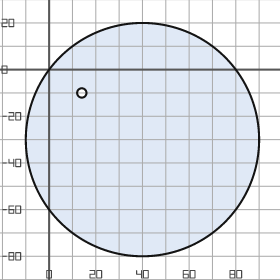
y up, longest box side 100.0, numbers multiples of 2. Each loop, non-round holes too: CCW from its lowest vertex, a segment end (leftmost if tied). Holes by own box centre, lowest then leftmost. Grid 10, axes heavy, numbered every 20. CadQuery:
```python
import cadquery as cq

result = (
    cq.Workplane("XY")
    .moveTo(40.0, -30.0)
    .circle(50.0)
    .moveTo(14.0, -10.0)
    .circle(2.0)
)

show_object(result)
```